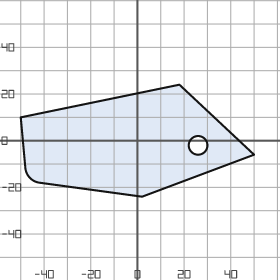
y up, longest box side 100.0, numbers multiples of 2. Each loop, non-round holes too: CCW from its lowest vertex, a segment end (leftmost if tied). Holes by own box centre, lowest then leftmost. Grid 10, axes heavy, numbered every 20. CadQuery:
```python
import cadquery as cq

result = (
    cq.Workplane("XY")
    .moveTo(2.0, -24.0)
    .lineTo(50.0, -6.0)
    .lineTo(18.0, 24.0)
    .lineTo(-50.0, 10.0)
    .lineTo(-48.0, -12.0)
    .threePointArc((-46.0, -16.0), (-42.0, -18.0))
    .close()
    .moveTo(26.0, -2.0)
    .circle(4.0)
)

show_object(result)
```